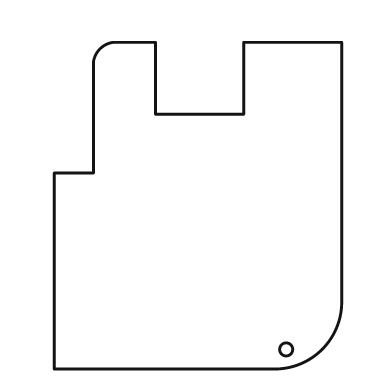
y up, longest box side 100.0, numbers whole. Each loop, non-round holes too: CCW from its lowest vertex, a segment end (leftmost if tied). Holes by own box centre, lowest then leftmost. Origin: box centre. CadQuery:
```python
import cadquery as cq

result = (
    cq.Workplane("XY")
    .moveTo(-44.0, -50.0)
    .lineTo(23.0, -50.0)
    .threePointArc((38.0, -44.0), (44.0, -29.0))
    .lineTo(44.0, 50.0)
    .lineTo(14.0, 50.0)
    .lineTo(14.0, 28.0)
    .lineTo(-13.0, 28.0)
    .lineTo(-13.0, 50.0)
    .lineTo(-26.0, 50.0)
    .threePointArc((-30.0, 48.0), (-32.0, 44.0))
    .lineTo(-32.0, 10.0)
    .lineTo(-44.0, 10.0)
    .close()
    .moveTo(27.0, -44.0)
    .circle(2.0)
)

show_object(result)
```